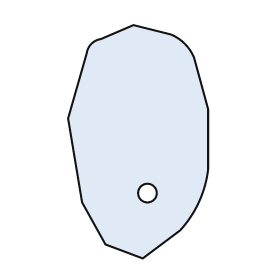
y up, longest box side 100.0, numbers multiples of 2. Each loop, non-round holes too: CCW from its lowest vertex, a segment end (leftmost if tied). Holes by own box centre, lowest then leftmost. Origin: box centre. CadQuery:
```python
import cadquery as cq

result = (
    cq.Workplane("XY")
    .moveTo(2.0, -50.0)
    .lineTo(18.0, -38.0)
    .threePointArc((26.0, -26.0), (30.0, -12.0))
    .lineTo(30.0, 14.0)
    .lineTo(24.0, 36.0)
    .threePointArc((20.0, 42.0), (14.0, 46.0))
    .lineTo(-2.0, 50.0)
    .lineTo(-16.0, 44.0)
    .threePointArc((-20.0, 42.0), (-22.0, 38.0))
    .lineTo(-30.0, 10.0)
    .lineTo(-24.0, -26.0)
    .lineTo(-14.0, -44.0)
    .close()
    .moveTo(4.0, -22.0)
    .circle(4.0)
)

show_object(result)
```